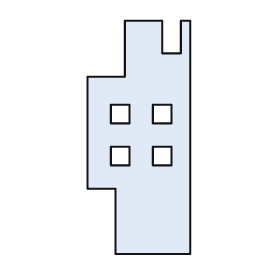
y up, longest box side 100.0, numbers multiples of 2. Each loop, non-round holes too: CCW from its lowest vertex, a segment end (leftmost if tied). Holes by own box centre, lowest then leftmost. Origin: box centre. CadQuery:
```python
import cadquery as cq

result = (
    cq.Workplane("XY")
    .moveTo(-10.0, -50.0)
    .lineTo(22.0, -50.0)
    .lineTo(22.0, 50.0)
    .lineTo(18.0, 50.0)
    .lineTo(18.0, 36.0)
    .lineTo(10.0, 36.0)
    .lineTo(10.0, 50.0)
    .lineTo(-6.0, 50.0)
    .lineTo(-6.0, 26.0)
    .lineTo(-22.0, 26.0)
    .lineTo(-22.0, -22.0)
    .lineTo(-10.0, -22.0)
    .close()
    .moveTo(-12.0, -12.0)
    .lineTo(-4.0, -12.0)
    .lineTo(-4.0, -4.0)
    .lineTo(-12.0, -4.0)
    .close()
    .moveTo(6.0, -12.0)
    .lineTo(14.0, -12.0)
    .lineTo(14.0, -4.0)
    .lineTo(6.0, -4.0)
    .close()
    .moveTo(-12.0, 6.0)
    .lineTo(-4.0, 6.0)
    .lineTo(-4.0, 14.0)
    .lineTo(-12.0, 14.0)
    .close()
    .moveTo(6.0, 6.0)
    .lineTo(14.0, 6.0)
    .lineTo(14.0, 14.0)
    .lineTo(6.0, 14.0)
    .close()
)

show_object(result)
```